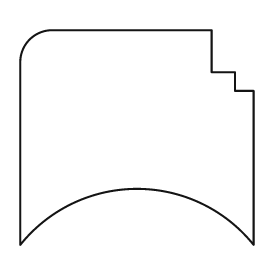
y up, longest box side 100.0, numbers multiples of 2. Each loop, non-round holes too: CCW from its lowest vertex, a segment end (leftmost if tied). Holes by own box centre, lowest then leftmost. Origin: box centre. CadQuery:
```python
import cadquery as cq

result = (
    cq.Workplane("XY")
    .moveTo(-50.0, -46.0)
    .threePointArc((0.0, -22.0), (50.0, -46.0))
    .lineTo(50.0, 20.0)
    .lineTo(42.0, 20.0)
    .lineTo(42.0, 28.0)
    .lineTo(32.0, 28.0)
    .lineTo(32.0, 46.0)
    .lineTo(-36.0, 46.0)
    .threePointArc((-46.0, 42.0), (-50.0, 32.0))
    .close()
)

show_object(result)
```